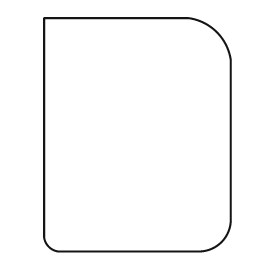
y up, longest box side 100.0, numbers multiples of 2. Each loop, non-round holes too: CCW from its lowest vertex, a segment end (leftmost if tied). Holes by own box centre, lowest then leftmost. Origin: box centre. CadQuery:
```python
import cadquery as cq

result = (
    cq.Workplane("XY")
    .moveTo(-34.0, -50.0)
    .lineTo(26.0, -50.0)
    .threePointArc((36.0, -46.0), (40.0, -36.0))
    .lineTo(40.0, 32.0)
    .threePointArc((34.0, 44.0), (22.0, 50.0))
    .lineTo(-40.0, 50.0)
    .lineTo(-40.0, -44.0)
    .threePointArc((-38.0, -48.0), (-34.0, -50.0))
    .close()
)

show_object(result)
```